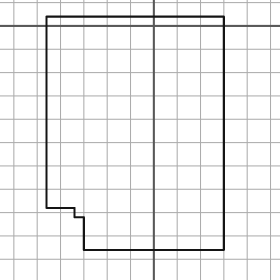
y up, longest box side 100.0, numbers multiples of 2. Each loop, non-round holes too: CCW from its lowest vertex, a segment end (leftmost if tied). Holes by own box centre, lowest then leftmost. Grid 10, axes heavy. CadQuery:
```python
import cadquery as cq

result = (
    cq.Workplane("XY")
    .moveTo(-30.0, -96.0)
    .lineTo(30.0, -96.0)
    .lineTo(30.0, 4.0)
    .lineTo(-46.0, 4.0)
    .lineTo(-46.0, -78.0)
    .lineTo(-34.0, -78.0)
    .lineTo(-34.0, -82.0)
    .lineTo(-30.0, -82.0)
    .close()
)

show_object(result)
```